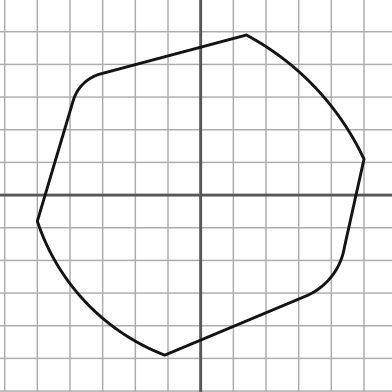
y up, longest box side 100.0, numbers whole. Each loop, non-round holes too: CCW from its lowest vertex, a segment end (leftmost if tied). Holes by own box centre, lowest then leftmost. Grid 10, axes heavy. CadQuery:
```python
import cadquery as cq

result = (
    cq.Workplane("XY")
    .moveTo(-11.0, -49.0)
    .lineTo(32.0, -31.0)
    .threePointArc((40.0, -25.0), (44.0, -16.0))
    .lineTo(50.0, 11.0)
    .threePointArc((35.0, 33.0), (14.0, 49.0))
    .lineTo(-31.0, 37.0)
    .threePointArc((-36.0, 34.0), (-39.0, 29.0))
    .lineTo(-50.0, -8.0)
    .threePointArc((-35.0, -33.0), (-11.0, -49.0))
    .close()
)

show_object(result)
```